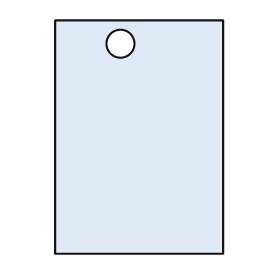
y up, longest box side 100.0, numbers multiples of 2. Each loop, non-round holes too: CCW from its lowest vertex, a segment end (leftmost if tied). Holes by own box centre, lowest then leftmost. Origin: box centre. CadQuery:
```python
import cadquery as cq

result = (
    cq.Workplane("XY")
    .moveTo(-36.0, -50.0)
    .lineTo(36.0, -50.0)
    .lineTo(36.0, 50.0)
    .lineTo(-36.0, 50.0)
    .close()
    .moveTo(-8.0, 40.0)
    .circle(6.0)
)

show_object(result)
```